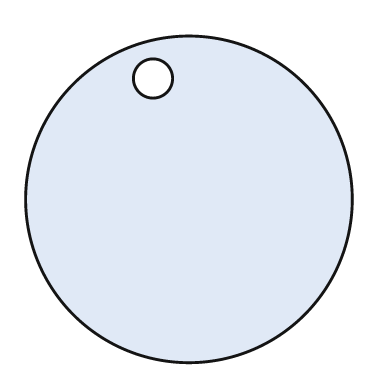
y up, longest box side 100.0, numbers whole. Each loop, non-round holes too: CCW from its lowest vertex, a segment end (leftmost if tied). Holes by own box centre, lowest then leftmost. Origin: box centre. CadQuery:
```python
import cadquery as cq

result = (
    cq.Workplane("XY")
    .moveTo(0.0, 0.0)
    .circle(50.0)
    .moveTo(-11.0, 37.0)
    .circle(6.0)
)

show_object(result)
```